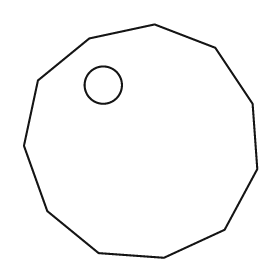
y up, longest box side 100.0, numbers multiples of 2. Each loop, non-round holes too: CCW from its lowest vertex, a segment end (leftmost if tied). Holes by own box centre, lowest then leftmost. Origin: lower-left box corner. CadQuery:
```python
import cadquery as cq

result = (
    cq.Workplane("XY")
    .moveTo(60.0, 0.0)
    .lineTo(86.0, 12.0)
    .lineTo(100.0, 38.0)
    .lineTo(98.0, 66.0)
    .lineTo(82.0, 90.0)
    .lineTo(56.0, 100.0)
    .lineTo(28.0, 94.0)
    .lineTo(6.0, 76.0)
    .lineTo(0.0, 48.0)
    .lineTo(10.0, 20.0)
    .lineTo(32.0, 2.0)
    .close()
    .moveTo(34.0, 74.0)
    .circle(8.0)
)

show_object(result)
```